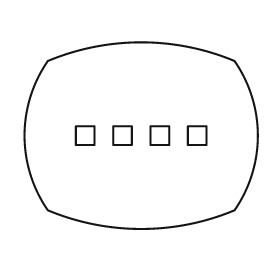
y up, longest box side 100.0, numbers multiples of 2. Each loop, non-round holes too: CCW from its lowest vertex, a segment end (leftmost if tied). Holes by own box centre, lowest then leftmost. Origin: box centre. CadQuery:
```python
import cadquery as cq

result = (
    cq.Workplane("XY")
    .moveTo(-40.0, -32.0)
    .threePointArc((0.0, -40.0), (40.0, -32.0))
    .threePointArc((50.0, 0.0), (40.0, 32.0))
    .threePointArc((0.0, 40.0), (-40.0, 32.0))
    .threePointArc((-50.0, 0.0), (-40.0, -32.0))
    .close()
    .moveTo(-28.0, -4.0)
    .lineTo(-20.0, -4.0)
    .lineTo(-20.0, 4.0)
    .lineTo(-28.0, 4.0)
    .close()
    .moveTo(-12.0, -4.0)
    .lineTo(-4.0, -4.0)
    .lineTo(-4.0, 4.0)
    .lineTo(-12.0, 4.0)
    .close()
    .moveTo(4.0, -4.0)
    .lineTo(12.0, -4.0)
    .lineTo(12.0, 4.0)
    .lineTo(4.0, 4.0)
    .close()
    .moveTo(20.0, -4.0)
    .lineTo(28.0, -4.0)
    .lineTo(28.0, 4.0)
    .lineTo(20.0, 4.0)
    .close()
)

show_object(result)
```